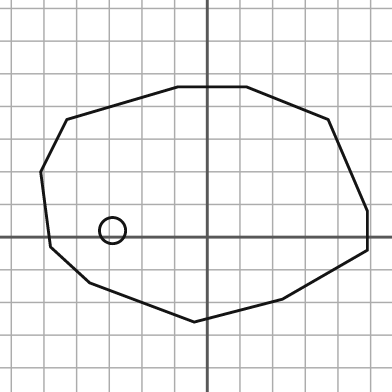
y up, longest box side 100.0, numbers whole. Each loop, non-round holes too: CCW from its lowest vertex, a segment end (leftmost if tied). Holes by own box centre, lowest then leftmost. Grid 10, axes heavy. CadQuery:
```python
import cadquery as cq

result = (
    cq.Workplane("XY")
    .moveTo(-4.0, -26.0)
    .lineTo(23.0, -19.0)
    .lineTo(49.0, -4.0)
    .lineTo(49.0, 8.0)
    .lineTo(37.0, 36.0)
    .lineTo(12.0, 46.0)
    .lineTo(-9.0, 46.0)
    .lineTo(-43.0, 36.0)
    .lineTo(-51.0, 20.0)
    .lineTo(-48.0, -3.0)
    .lineTo(-36.0, -14.0)
    .close()
    .moveTo(-29.0, 2.0)
    .circle(4.0)
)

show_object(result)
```